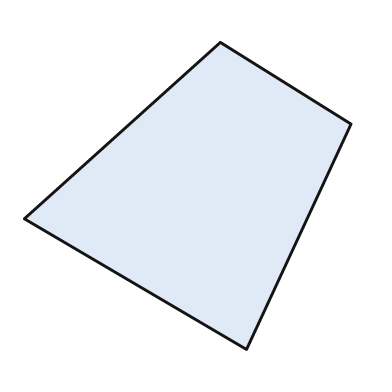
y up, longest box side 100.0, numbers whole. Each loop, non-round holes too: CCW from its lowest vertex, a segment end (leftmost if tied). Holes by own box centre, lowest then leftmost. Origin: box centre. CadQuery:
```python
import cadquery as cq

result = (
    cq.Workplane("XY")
    .moveTo(18.0, -47.0)
    .lineTo(50.0, 22.0)
    .lineTo(10.0, 47.0)
    .lineTo(-50.0, -7.0)
    .close()
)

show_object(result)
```